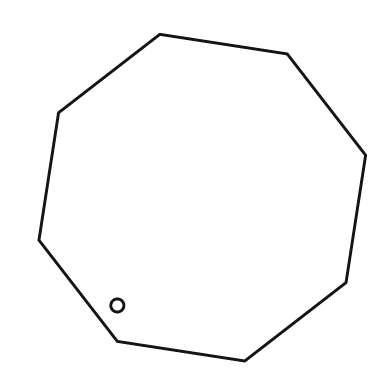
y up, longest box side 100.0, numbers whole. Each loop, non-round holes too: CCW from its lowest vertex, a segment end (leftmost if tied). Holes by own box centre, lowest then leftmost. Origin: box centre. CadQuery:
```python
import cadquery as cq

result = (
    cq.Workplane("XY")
    .moveTo(13.0, -50.0)
    .lineTo(44.0, -26.0)
    .lineTo(50.0, 13.0)
    .lineTo(26.0, 44.0)
    .lineTo(-13.0, 50.0)
    .lineTo(-44.0, 26.0)
    .lineTo(-50.0, -13.0)
    .lineTo(-26.0, -44.0)
    .close()
    .moveTo(-26.0, -33.0)
    .circle(2.0)
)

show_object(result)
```